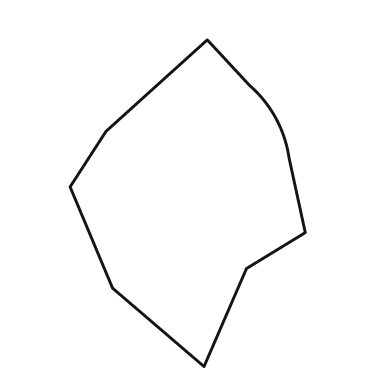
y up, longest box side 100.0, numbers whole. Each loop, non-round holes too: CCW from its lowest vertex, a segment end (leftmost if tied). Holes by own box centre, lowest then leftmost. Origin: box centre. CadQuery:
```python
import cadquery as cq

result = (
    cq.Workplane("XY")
    .moveTo(5.0, -50.0)
    .lineTo(18.0, -20.0)
    .lineTo(36.0, -9.0)
    .lineTo(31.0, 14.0)
    .threePointArc((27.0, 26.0), (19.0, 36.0))
    .lineTo(6.0, 50.0)
    .lineTo(-25.0, 22.0)
    .lineTo(-36.0, 5.0)
    .lineTo(-23.0, -26.0)
    .close()
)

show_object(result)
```